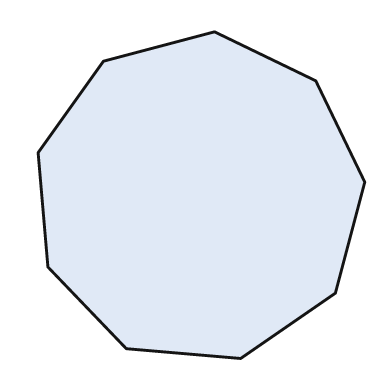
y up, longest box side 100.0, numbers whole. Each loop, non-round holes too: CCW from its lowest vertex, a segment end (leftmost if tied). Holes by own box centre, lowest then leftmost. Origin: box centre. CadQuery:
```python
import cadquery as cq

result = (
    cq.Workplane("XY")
    .moveTo(12.0, -50.0)
    .lineTo(41.0, -30.0)
    .lineTo(50.0, 4.0)
    .lineTo(35.0, 35.0)
    .lineTo(4.0, 50.0)
    .lineTo(-30.0, 41.0)
    .lineTo(-50.0, 13.0)
    .lineTo(-47.0, -22.0)
    .lineTo(-23.0, -47.0)
    .close()
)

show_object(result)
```